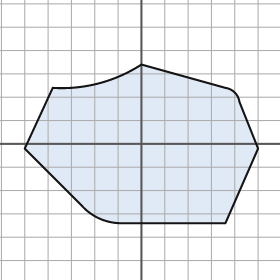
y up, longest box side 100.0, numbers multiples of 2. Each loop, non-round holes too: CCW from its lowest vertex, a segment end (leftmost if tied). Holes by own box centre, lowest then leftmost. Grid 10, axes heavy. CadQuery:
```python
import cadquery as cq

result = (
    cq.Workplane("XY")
    .moveTo(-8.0, -34.0)
    .lineTo(36.0, -34.0)
    .lineTo(50.0, -2.0)
    .lineTo(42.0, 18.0)
    .threePointArc((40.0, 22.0), (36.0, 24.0))
    .lineTo(0.0, 34.0)
    .threePointArc((-18.0, 26.0), (-38.0, 24.0))
    .lineTo(-50.0, -2.0)
    .lineTo(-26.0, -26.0)
    .threePointArc((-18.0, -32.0), (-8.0, -34.0))
    .close()
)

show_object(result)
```